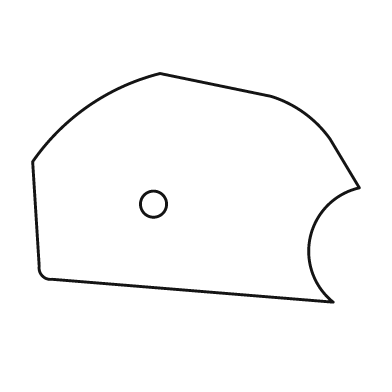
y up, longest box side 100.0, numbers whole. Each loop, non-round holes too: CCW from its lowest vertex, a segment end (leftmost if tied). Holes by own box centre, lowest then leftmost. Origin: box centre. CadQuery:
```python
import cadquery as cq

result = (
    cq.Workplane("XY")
    .moveTo(42.0, -35.0)
    .threePointArc((35.0, -15.0), (50.0, 0.0))
    .lineTo(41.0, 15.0)
    .threePointArc((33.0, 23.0), (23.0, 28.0))
    .lineTo(-11.0, 35.0)
    .threePointArc((-33.0, 25.0), (-50.0, 8.0))
    .lineTo(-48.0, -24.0)
    .threePointArc((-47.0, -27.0), (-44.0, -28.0))
    .close()
    .moveTo(-13.0, -5.0)
    .circle(4.0)
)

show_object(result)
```